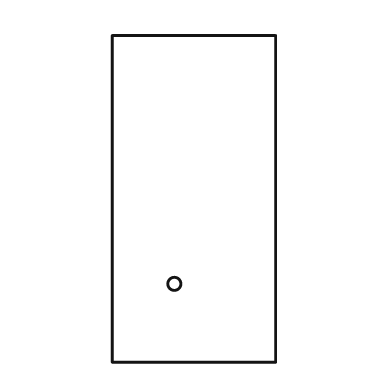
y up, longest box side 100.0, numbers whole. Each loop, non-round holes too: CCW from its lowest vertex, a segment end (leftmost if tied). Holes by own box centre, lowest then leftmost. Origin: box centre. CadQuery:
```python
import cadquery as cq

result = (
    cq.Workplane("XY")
    .moveTo(-25.0, -50.0)
    .lineTo(25.0, -50.0)
    .lineTo(25.0, 50.0)
    .lineTo(-25.0, 50.0)
    .close()
    .moveTo(-6.0, -26.0)
    .circle(2.0)
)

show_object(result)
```